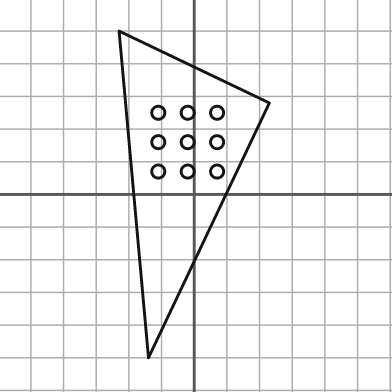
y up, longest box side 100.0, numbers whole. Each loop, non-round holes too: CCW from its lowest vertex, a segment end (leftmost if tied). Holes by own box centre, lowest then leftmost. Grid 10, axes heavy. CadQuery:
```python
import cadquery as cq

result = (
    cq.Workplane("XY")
    .moveTo(-14.0, -50.0)
    .lineTo(23.0, 28.0)
    .lineTo(-23.0, 50.0)
    .close()
    .moveTo(-11.0, 7.0)
    .circle(2.0)
    .moveTo(-2.0, 7.0)
    .circle(2.0)
    .moveTo(7.0, 7.0)
    .circle(2.0)
    .moveTo(-11.0, 16.0)
    .circle(2.0)
    .moveTo(-2.0, 16.0)
    .circle(2.0)
    .moveTo(7.0, 16.0)
    .circle(2.0)
    .moveTo(-11.0, 25.0)
    .circle(2.0)
    .moveTo(-2.0, 25.0)
    .circle(2.0)
    .moveTo(7.0, 25.0)
    .circle(2.0)
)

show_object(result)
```